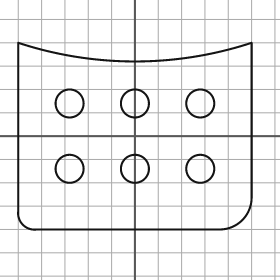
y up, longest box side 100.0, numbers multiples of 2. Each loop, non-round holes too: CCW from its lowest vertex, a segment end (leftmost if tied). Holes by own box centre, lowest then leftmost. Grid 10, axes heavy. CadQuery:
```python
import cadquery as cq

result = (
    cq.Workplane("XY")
    .moveTo(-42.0, -40.0)
    .lineTo(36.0, -40.0)
    .threePointArc((46.0, -36.0), (50.0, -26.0))
    .lineTo(50.0, 40.0)
    .threePointArc((0.0, 32.0), (-50.0, 40.0))
    .lineTo(-50.0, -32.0)
    .threePointArc((-48.0, -38.0), (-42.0, -40.0))
    .close()
    .moveTo(-28.0, -14.0)
    .circle(6.0)
    .moveTo(0.0, -14.0)
    .circle(6.0)
    .moveTo(28.0, -14.0)
    .circle(6.0)
    .moveTo(-28.0, 14.0)
    .circle(6.0)
    .moveTo(0.0, 14.0)
    .circle(6.0)
    .moveTo(28.0, 14.0)
    .circle(6.0)
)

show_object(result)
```